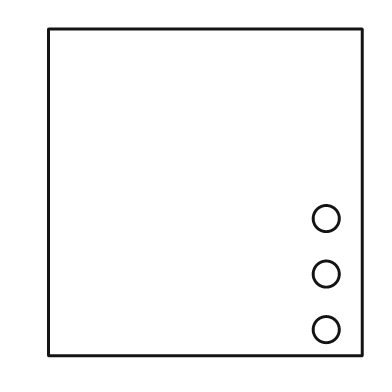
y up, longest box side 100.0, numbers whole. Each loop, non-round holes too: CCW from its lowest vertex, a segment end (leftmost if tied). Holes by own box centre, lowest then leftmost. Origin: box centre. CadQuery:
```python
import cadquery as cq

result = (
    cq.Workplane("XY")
    .moveTo(-48.0, -50.0)
    .lineTo(48.0, -50.0)
    .lineTo(48.0, 50.0)
    .lineTo(-48.0, 50.0)
    .close()
    .moveTo(37.0, -42.0)
    .circle(4.0)
    .moveTo(37.0, -25.0)
    .circle(4.0)
    .moveTo(37.0, -8.0)
    .circle(4.0)
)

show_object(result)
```